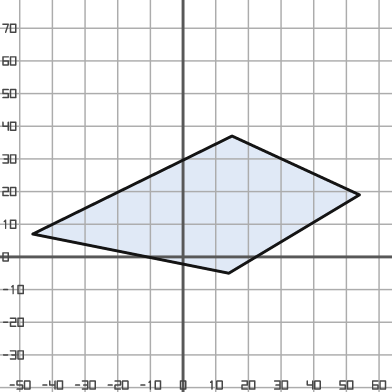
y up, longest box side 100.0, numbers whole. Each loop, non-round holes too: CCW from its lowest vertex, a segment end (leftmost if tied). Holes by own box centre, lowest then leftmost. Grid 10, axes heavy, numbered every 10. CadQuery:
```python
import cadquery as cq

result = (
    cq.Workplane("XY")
    .moveTo(14.0, -5.0)
    .lineTo(54.0, 19.0)
    .lineTo(15.0, 37.0)
    .lineTo(-46.0, 7.0)
    .close()
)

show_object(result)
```